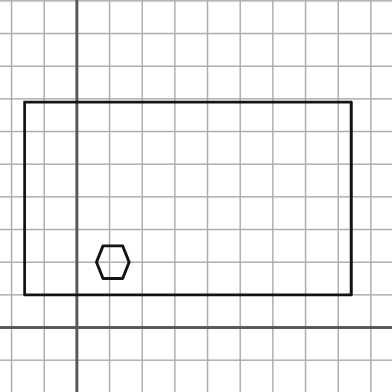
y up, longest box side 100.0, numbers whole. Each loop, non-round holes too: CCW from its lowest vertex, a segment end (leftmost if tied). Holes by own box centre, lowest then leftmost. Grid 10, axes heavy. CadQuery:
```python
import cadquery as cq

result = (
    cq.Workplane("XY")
    .moveTo(-16.0, 10.0)
    .lineTo(84.0, 10.0)
    .lineTo(84.0, 69.0)
    .lineTo(-16.0, 69.0)
    .close()
    .moveTo(8.0, 15.0)
    .lineTo(14.0, 15.0)
    .lineTo(16.0, 20.0)
    .lineTo(14.0, 25.0)
    .lineTo(8.0, 25.0)
    .lineTo(6.0, 20.0)
    .close()
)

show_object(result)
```